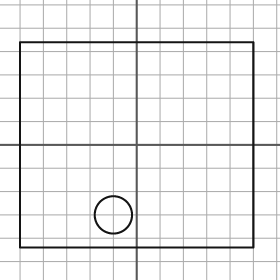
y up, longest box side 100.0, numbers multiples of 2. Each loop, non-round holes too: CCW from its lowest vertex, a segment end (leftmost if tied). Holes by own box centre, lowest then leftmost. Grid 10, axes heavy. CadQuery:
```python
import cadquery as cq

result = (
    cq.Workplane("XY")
    .moveTo(-50.0, -44.0)
    .lineTo(50.0, -44.0)
    .lineTo(50.0, 44.0)
    .lineTo(-50.0, 44.0)
    .close()
    .moveTo(-10.0, -30.0)
    .circle(8.0)
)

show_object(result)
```